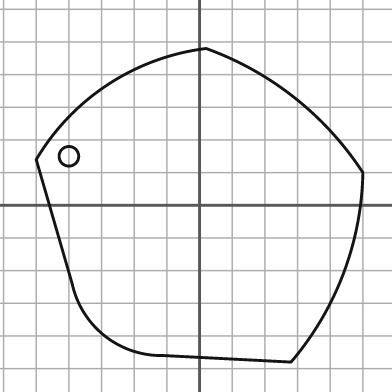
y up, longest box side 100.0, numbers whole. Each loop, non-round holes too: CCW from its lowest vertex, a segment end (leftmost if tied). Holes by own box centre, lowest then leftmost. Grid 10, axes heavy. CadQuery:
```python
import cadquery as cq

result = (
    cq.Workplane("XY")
    .moveTo(28.0, -48.0)
    .threePointArc((44.0, -21.0), (50.0, 10.0))
    .threePointArc((29.0, 33.0), (2.0, 48.0))
    .threePointArc((-28.0, 37.0), (-50.0, 14.0))
    .lineTo(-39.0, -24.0)
    .threePointArc((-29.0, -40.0), (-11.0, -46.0))
    .close()
    .moveTo(-40.0, 15.0)
    .circle(3.0)
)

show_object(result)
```